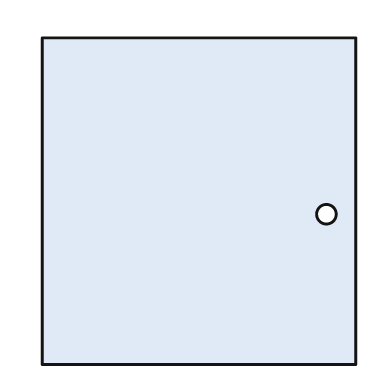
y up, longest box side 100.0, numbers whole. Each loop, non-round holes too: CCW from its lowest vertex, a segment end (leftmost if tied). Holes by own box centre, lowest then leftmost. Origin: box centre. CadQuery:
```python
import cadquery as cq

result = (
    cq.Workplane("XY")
    .moveTo(-48.0, -50.0)
    .lineTo(48.0, -50.0)
    .lineTo(48.0, 50.0)
    .lineTo(-48.0, 50.0)
    .close()
    .moveTo(39.0, -4.0)
    .circle(3.0)
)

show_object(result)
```